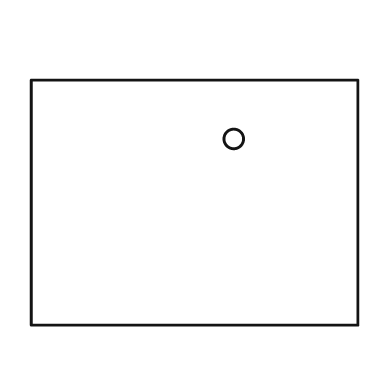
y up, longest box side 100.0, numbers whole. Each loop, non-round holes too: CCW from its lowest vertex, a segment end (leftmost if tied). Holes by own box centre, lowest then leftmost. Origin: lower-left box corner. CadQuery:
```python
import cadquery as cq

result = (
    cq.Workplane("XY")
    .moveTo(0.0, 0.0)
    .lineTo(100.0, 0.0)
    .lineTo(100.0, 75.0)
    .lineTo(0.0, 75.0)
    .close()
    .moveTo(62.0, 57.0)
    .circle(3.0)
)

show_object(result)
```